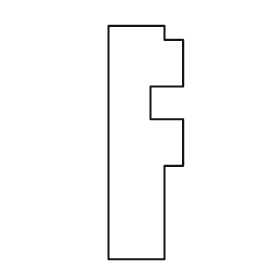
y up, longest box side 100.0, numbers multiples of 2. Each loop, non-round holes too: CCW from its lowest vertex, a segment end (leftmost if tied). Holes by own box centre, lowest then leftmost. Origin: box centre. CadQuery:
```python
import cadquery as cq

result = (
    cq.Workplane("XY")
    .moveTo(-16.0, -50.0)
    .lineTo(8.0, -50.0)
    .lineTo(8.0, -10.0)
    .lineTo(16.0, -10.0)
    .lineTo(16.0, 10.0)
    .lineTo(2.0, 10.0)
    .lineTo(2.0, 24.0)
    .lineTo(16.0, 24.0)
    .lineTo(16.0, 44.0)
    .lineTo(8.0, 44.0)
    .lineTo(8.0, 50.0)
    .lineTo(-16.0, 50.0)
    .close()
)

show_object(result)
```